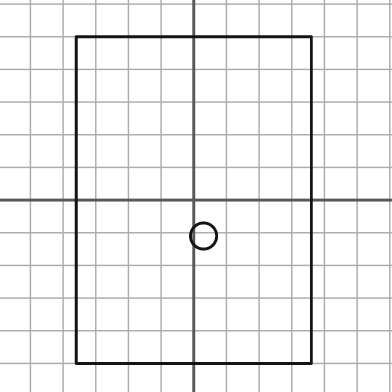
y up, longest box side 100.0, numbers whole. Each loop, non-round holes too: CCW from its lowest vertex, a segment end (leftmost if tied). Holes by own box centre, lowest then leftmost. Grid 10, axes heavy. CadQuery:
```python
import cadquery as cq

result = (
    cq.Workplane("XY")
    .moveTo(-36.0, -50.0)
    .lineTo(36.0, -50.0)
    .lineTo(36.0, 50.0)
    .lineTo(-36.0, 50.0)
    .close()
    .moveTo(3.0, -11.0)
    .circle(4.0)
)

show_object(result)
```